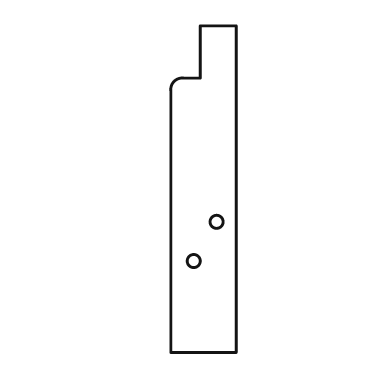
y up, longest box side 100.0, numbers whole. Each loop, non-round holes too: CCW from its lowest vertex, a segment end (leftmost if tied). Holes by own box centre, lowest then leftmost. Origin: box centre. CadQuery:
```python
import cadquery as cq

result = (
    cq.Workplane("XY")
    .moveTo(-10.0, -50.0)
    .lineTo(10.0, -50.0)
    .lineTo(10.0, 50.0)
    .lineTo(-1.0, 50.0)
    .lineTo(-1.0, 34.0)
    .lineTo(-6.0, 34.0)
    .threePointArc((-9.0, 33.0), (-10.0, 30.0))
    .close()
    .moveTo(-3.0, -22.0)
    .circle(2.0)
    .moveTo(4.0, -10.0)
    .circle(2.0)
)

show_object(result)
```